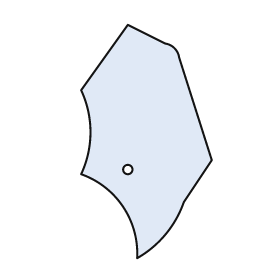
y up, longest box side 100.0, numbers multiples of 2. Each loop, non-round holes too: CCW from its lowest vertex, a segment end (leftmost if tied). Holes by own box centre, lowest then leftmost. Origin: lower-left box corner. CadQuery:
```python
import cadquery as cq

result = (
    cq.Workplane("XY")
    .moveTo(24.0, 0.0)
    .threePointArc((36.0, 10.0), (44.0, 24.0))
    .lineTo(56.0, 42.0)
    .lineTo(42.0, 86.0)
    .threePointArc((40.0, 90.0), (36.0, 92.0))
    .lineTo(20.0, 100.0)
    .lineTo(0.0, 72.0)
    .threePointArc((4.0, 54.0), (0.0, 36.0))
    .threePointArc((18.0, 22.0), (24.0, 0.0))
    .close()
    .moveTo(20.0, 38.0)
    .circle(2.0)
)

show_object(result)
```